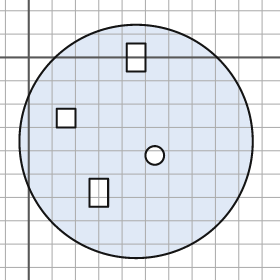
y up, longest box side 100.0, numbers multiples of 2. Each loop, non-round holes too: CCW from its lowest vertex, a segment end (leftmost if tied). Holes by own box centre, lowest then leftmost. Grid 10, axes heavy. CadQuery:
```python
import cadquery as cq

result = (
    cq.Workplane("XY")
    .moveTo(46.0, -36.0)
    .circle(50.0)
    .moveTo(26.0, -64.0)
    .lineTo(34.0, -64.0)
    .lineTo(34.0, -52.0)
    .lineTo(26.0, -52.0)
    .close()
    .moveTo(54.0, -42.0)
    .circle(4.0)
    .moveTo(12.0, -30.0)
    .lineTo(20.0, -30.0)
    .lineTo(20.0, -22.0)
    .lineTo(12.0, -22.0)
    .close()
    .moveTo(42.0, -6.0)
    .lineTo(50.0, -6.0)
    .lineTo(50.0, 6.0)
    .lineTo(42.0, 6.0)
    .close()
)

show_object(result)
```